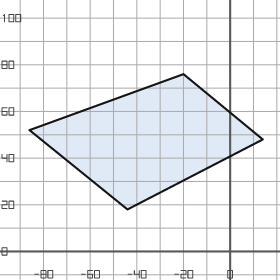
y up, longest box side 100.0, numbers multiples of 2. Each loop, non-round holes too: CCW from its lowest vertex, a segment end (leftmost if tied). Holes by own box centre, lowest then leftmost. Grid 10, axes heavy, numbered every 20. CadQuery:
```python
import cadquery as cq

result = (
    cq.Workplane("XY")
    .moveTo(-44.0, 18.0)
    .lineTo(14.0, 48.0)
    .lineTo(-20.0, 76.0)
    .lineTo(-86.0, 52.0)
    .close()
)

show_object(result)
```